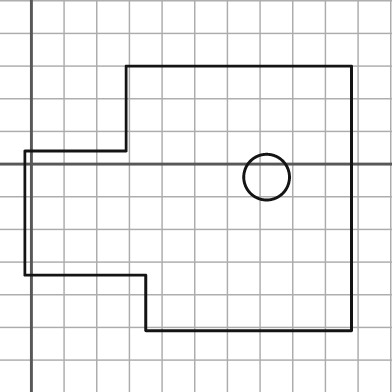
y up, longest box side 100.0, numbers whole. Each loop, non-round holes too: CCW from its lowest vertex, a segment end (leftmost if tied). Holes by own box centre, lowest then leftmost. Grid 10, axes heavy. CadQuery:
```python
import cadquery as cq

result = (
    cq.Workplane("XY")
    .moveTo(35.0, -51.0)
    .lineTo(98.0, -51.0)
    .lineTo(98.0, 30.0)
    .lineTo(29.0, 30.0)
    .lineTo(29.0, 4.0)
    .lineTo(-2.0, 4.0)
    .lineTo(-2.0, -34.0)
    .lineTo(35.0, -34.0)
    .close()
    .moveTo(72.0, -4.0)
    .circle(7.0)
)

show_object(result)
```